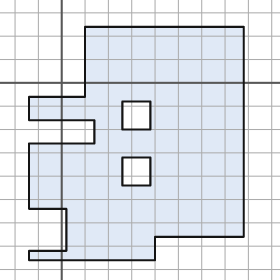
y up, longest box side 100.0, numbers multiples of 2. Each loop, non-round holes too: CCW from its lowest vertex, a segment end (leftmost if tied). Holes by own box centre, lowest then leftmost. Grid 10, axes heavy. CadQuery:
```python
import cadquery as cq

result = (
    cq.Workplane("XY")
    .moveTo(-14.0, -76.0)
    .lineTo(40.0, -76.0)
    .lineTo(40.0, -66.0)
    .lineTo(78.0, -66.0)
    .lineTo(78.0, 24.0)
    .lineTo(10.0, 24.0)
    .lineTo(10.0, -6.0)
    .lineTo(-14.0, -6.0)
    .lineTo(-14.0, -16.0)
    .lineTo(14.0, -16.0)
    .lineTo(14.0, -26.0)
    .lineTo(-14.0, -26.0)
    .lineTo(-14.0, -54.0)
    .lineTo(2.0, -54.0)
    .lineTo(2.0, -72.0)
    .lineTo(-14.0, -72.0)
    .close()
    .moveTo(26.0, -44.0)
    .lineTo(38.0, -44.0)
    .lineTo(38.0, -32.0)
    .lineTo(26.0, -32.0)
    .close()
    .moveTo(26.0, -20.0)
    .lineTo(38.0, -20.0)
    .lineTo(38.0, -8.0)
    .lineTo(26.0, -8.0)
    .close()
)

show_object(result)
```